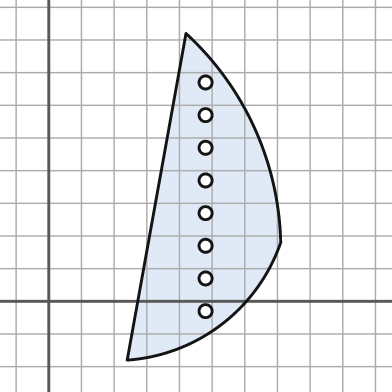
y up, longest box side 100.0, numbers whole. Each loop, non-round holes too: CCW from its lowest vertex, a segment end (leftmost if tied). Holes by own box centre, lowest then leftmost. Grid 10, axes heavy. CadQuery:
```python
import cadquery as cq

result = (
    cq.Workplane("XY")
    .moveTo(24.0, -18.0)
    .threePointArc((53.0, -7.0), (71.0, 18.0))
    .threePointArc((63.0, 53.0), (42.0, 82.0))
    .close()
    .moveTo(48.0, -3.0)
    .circle(2.0)
    .moveTo(48.0, 7.0)
    .circle(2.0)
    .moveTo(48.0, 17.0)
    .circle(2.0)
    .moveTo(48.0, 27.0)
    .circle(2.0)
    .moveTo(48.0, 37.0)
    .circle(2.0)
    .moveTo(48.0, 47.0)
    .circle(2.0)
    .moveTo(48.0, 57.0)
    .circle(2.0)
    .moveTo(48.0, 67.0)
    .circle(2.0)
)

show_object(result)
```